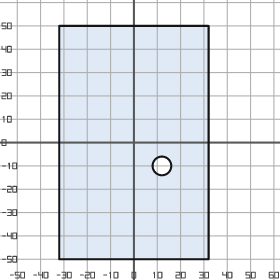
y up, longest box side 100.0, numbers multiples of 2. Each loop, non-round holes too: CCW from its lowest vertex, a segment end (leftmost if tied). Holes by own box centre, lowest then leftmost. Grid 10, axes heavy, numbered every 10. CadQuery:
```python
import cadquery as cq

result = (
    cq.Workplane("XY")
    .moveTo(-32.0, -50.0)
    .lineTo(32.0, -50.0)
    .lineTo(32.0, 50.0)
    .lineTo(-32.0, 50.0)
    .close()
    .moveTo(12.0, -10.0)
    .circle(4.0)
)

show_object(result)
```